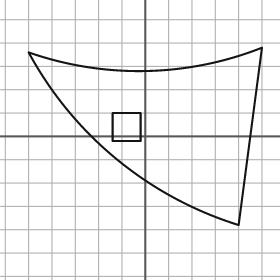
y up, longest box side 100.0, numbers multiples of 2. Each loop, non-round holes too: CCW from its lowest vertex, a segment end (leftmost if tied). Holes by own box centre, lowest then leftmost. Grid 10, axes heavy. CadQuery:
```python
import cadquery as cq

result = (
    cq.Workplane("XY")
    .moveTo(40.0, -38.0)
    .lineTo(50.0, 38.0)
    .threePointArc((0.0, 28.0), (-50.0, 36.0))
    .threePointArc((-12.0, -10.0), (40.0, -38.0))
    .close()
    .moveTo(-14.0, -2.0)
    .lineTo(-2.0, -2.0)
    .lineTo(-2.0, 10.0)
    .lineTo(-14.0, 10.0)
    .close()
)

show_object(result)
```